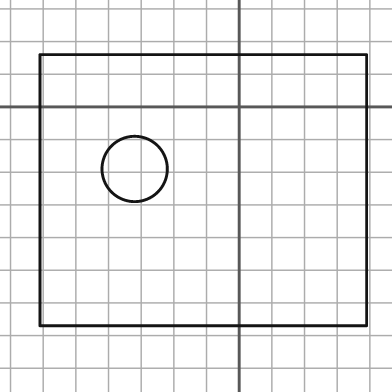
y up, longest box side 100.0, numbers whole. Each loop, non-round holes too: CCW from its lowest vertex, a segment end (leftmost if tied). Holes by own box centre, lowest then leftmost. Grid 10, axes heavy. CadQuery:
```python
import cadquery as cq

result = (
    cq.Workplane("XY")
    .moveTo(-61.0, -67.0)
    .lineTo(39.0, -67.0)
    .lineTo(39.0, 16.0)
    .lineTo(-61.0, 16.0)
    .close()
    .moveTo(-32.0, -19.0)
    .circle(10.0)
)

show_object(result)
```